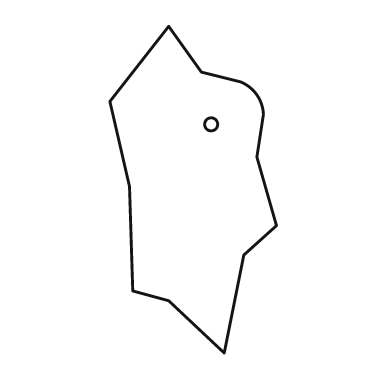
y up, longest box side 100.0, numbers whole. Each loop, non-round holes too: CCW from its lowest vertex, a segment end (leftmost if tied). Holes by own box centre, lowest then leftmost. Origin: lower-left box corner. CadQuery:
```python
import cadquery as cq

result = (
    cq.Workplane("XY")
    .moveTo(35.0, 0.0)
    .lineTo(41.0, 30.0)
    .lineTo(51.0, 39.0)
    .lineTo(45.0, 60.0)
    .lineTo(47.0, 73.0)
    .threePointArc((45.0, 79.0), (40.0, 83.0))
    .lineTo(28.0, 86.0)
    .lineTo(18.0, 100.0)
    .lineTo(0.0, 77.0)
    .lineTo(6.0, 51.0)
    .lineTo(7.0, 19.0)
    .lineTo(18.0, 16.0)
    .close()
    .moveTo(31.0, 70.0)
    .circle(2.0)
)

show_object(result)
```